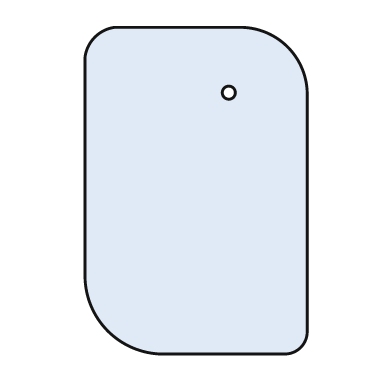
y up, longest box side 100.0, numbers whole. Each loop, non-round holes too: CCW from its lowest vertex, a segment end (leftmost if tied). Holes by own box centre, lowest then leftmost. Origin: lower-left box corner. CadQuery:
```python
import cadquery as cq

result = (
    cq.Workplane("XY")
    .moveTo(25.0, 0.0)
    .lineTo(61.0, 0.0)
    .threePointArc((66.0, 2.0), (68.0, 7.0))
    .lineTo(68.0, 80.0)
    .threePointArc((62.0, 94.0), (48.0, 100.0))
    .lineTo(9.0, 100.0)
    .threePointArc((3.0, 97.0), (0.0, 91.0))
    .lineTo(0.0, 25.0)
    .threePointArc((7.0, 7.0), (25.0, 0.0))
    .close()
    .moveTo(44.0, 80.0)
    .circle(2.0)
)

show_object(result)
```